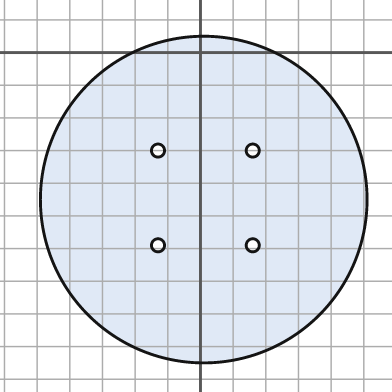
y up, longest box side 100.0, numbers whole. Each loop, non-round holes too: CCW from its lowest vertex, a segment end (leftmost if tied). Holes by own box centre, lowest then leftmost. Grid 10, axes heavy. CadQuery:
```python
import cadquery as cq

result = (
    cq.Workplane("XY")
    .moveTo(1.0, -45.0)
    .circle(50.0)
    .moveTo(-13.0, -59.0)
    .circle(2.0)
    .moveTo(16.0, -59.0)
    .circle(2.0)
    .moveTo(-13.0, -30.0)
    .circle(2.0)
    .moveTo(16.0, -30.0)
    .circle(2.0)
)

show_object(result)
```